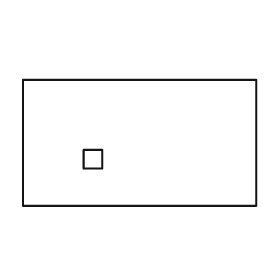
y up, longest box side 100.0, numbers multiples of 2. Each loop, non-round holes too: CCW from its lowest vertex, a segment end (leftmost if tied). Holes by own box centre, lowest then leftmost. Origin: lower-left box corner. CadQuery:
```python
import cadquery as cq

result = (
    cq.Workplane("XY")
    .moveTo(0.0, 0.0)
    .lineTo(100.0, 0.0)
    .lineTo(100.0, 54.0)
    .lineTo(0.0, 54.0)
    .close()
    .moveTo(26.0, 16.0)
    .lineTo(34.0, 16.0)
    .lineTo(34.0, 24.0)
    .lineTo(26.0, 24.0)
    .close()
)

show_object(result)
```